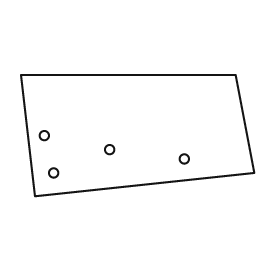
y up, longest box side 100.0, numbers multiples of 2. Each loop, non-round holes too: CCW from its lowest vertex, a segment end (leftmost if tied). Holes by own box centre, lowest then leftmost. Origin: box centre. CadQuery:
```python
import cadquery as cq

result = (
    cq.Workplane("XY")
    .moveTo(-44.0, -26.0)
    .lineTo(50.0, -16.0)
    .lineTo(42.0, 26.0)
    .lineTo(-50.0, 26.0)
    .close()
    .moveTo(-36.0, -16.0)
    .circle(2.0)
    .moveTo(20.0, -10.0)
    .circle(2.0)
    .moveTo(-12.0, -6.0)
    .circle(2.0)
    .moveTo(-40.0, 0.0)
    .circle(2.0)
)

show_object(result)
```